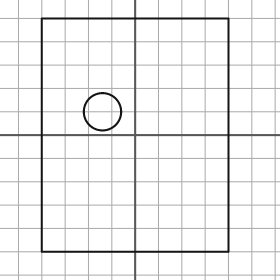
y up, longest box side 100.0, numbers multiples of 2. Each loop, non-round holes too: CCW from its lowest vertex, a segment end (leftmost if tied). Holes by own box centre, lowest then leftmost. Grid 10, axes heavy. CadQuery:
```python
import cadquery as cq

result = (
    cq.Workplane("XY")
    .moveTo(-40.0, -50.0)
    .lineTo(40.0, -50.0)
    .lineTo(40.0, 50.0)
    .lineTo(-40.0, 50.0)
    .close()
    .moveTo(-14.0, 10.0)
    .circle(8.0)
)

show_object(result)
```